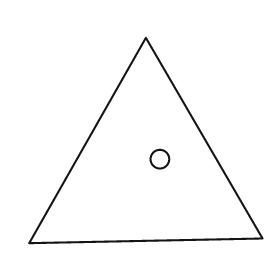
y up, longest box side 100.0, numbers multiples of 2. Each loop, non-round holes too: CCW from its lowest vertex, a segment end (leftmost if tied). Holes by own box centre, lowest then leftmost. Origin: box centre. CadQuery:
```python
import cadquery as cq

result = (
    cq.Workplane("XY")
    .moveTo(-50.0, -44.0)
    .lineTo(50.0, -42.0)
    .lineTo(0.0, 44.0)
    .close()
    .moveTo(6.0, -8.0)
    .circle(4.0)
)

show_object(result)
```